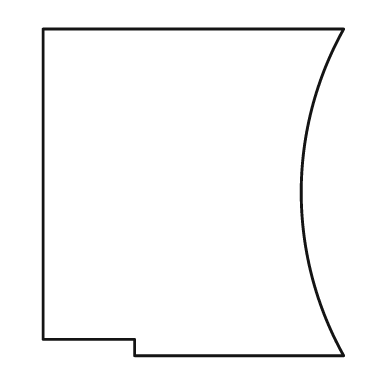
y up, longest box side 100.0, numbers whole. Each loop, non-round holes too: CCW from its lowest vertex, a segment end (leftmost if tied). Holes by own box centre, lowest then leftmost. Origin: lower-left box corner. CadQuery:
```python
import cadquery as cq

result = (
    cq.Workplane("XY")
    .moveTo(28.0, 0.0)
    .lineTo(92.0, 0.0)
    .threePointArc((79.0, 50.0), (92.0, 100.0))
    .lineTo(0.0, 100.0)
    .lineTo(0.0, 5.0)
    .lineTo(28.0, 5.0)
    .close()
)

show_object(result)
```